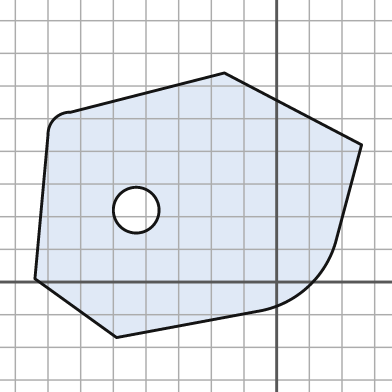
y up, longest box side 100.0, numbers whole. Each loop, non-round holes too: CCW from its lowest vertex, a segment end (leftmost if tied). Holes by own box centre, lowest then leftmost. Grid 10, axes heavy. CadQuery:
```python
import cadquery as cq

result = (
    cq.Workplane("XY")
    .moveTo(-49.0, -17.0)
    .lineTo(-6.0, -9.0)
    .threePointArc((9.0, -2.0), (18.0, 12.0))
    .lineTo(26.0, 42.0)
    .lineTo(-16.0, 64.0)
    .lineTo(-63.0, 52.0)
    .threePointArc((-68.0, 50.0), (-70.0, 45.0))
    .lineTo(-74.0, 1.0)
    .close()
    .moveTo(-43.0, 22.0)
    .circle(7.0)
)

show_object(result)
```